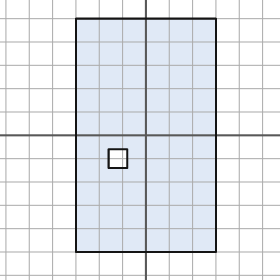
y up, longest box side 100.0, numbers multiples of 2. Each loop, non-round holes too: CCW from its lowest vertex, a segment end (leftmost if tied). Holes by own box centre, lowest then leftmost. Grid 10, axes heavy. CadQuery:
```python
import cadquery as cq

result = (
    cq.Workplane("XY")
    .moveTo(-30.0, -50.0)
    .lineTo(30.0, -50.0)
    .lineTo(30.0, 50.0)
    .lineTo(-30.0, 50.0)
    .close()
    .moveTo(-16.0, -14.0)
    .lineTo(-8.0, -14.0)
    .lineTo(-8.0, -6.0)
    .lineTo(-16.0, -6.0)
    .close()
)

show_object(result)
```